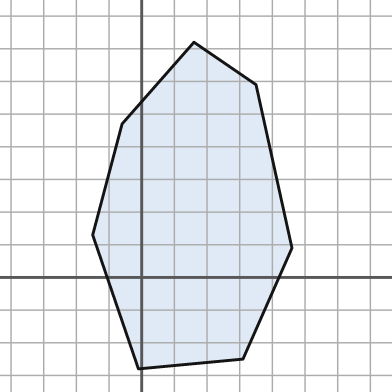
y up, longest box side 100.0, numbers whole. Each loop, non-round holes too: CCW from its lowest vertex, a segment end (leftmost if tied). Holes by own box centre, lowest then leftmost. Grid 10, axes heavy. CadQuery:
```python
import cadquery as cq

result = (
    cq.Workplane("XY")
    .moveTo(-1.0, -28.0)
    .lineTo(31.0, -25.0)
    .lineTo(46.0, 9.0)
    .lineTo(35.0, 59.0)
    .lineTo(16.0, 72.0)
    .lineTo(-6.0, 47.0)
    .lineTo(-15.0, 13.0)
    .close()
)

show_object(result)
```